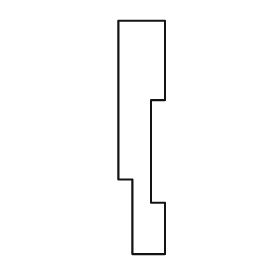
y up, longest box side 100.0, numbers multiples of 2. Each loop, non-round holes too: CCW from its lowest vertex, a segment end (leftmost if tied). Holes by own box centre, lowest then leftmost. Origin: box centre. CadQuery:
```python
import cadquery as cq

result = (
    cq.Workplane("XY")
    .moveTo(-4.0, -50.0)
    .lineTo(10.0, -50.0)
    .lineTo(10.0, -28.0)
    .lineTo(4.0, -28.0)
    .lineTo(4.0, 16.0)
    .lineTo(10.0, 16.0)
    .lineTo(10.0, 50.0)
    .lineTo(-10.0, 50.0)
    .lineTo(-10.0, -18.0)
    .lineTo(-4.0, -18.0)
    .close()
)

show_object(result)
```